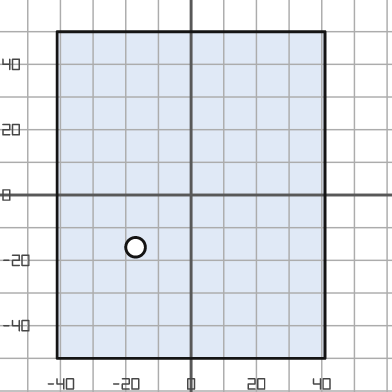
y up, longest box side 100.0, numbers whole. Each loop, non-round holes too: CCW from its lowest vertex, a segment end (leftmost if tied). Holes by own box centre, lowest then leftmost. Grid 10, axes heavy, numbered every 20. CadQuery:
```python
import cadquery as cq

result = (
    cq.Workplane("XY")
    .moveTo(-41.0, -50.0)
    .lineTo(41.0, -50.0)
    .lineTo(41.0, 50.0)
    .lineTo(-41.0, 50.0)
    .close()
    .moveTo(-17.0, -16.0)
    .circle(3.0)
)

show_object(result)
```